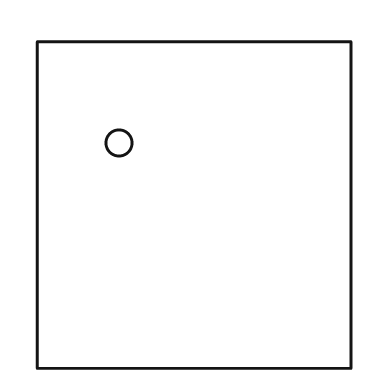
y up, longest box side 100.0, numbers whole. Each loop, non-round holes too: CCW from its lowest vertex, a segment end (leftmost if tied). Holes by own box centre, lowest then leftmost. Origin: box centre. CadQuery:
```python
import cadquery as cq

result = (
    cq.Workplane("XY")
    .moveTo(-48.0, -50.0)
    .lineTo(48.0, -50.0)
    .lineTo(48.0, 50.0)
    .lineTo(-48.0, 50.0)
    .close()
    .moveTo(-23.0, 19.0)
    .circle(4.0)
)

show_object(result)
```